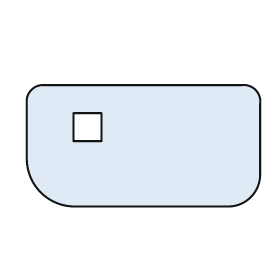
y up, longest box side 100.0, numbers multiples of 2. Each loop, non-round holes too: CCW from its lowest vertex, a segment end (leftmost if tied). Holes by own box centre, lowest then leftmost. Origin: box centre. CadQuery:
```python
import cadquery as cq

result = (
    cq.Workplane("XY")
    .moveTo(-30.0, -26.0)
    .lineTo(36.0, -26.0)
    .threePointArc((46.0, -22.0), (50.0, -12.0))
    .lineTo(50.0, 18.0)
    .threePointArc((48.0, 24.0), (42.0, 26.0))
    .lineTo(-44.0, 26.0)
    .threePointArc((-48.0, 24.0), (-50.0, 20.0))
    .lineTo(-50.0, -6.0)
    .threePointArc((-44.0, -20.0), (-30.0, -26.0))
    .close()
    .moveTo(-30.0, 2.0)
    .lineTo(-18.0, 2.0)
    .lineTo(-18.0, 14.0)
    .lineTo(-30.0, 14.0)
    .close()
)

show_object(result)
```